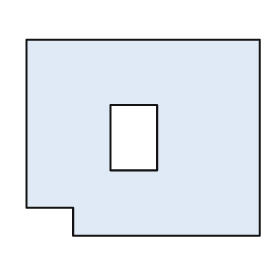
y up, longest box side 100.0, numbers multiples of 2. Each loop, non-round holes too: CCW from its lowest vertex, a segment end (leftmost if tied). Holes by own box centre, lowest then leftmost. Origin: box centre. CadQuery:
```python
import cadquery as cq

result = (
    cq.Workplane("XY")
    .moveTo(-30.0, -42.0)
    .lineTo(50.0, -42.0)
    .lineTo(50.0, 42.0)
    .lineTo(-50.0, 42.0)
    .lineTo(-50.0, -30.0)
    .lineTo(-30.0, -30.0)
    .close()
    .moveTo(-14.0, -14.0)
    .lineTo(6.0, -14.0)
    .lineTo(6.0, 14.0)
    .lineTo(-14.0, 14.0)
    .close()
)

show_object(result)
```